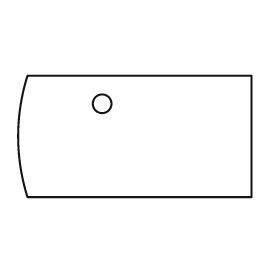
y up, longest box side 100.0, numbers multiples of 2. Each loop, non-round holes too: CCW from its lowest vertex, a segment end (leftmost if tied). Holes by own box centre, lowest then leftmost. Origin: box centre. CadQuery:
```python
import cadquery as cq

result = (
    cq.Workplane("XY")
    .moveTo(-46.0, -26.0)
    .lineTo(50.0, -26.0)
    .lineTo(50.0, 26.0)
    .lineTo(-46.0, 26.0)
    .threePointArc((-50.0, 0.0), (-46.0, -26.0))
    .close()
    .moveTo(-14.0, 14.0)
    .circle(4.0)
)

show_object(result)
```